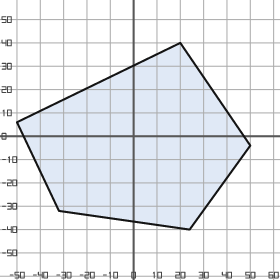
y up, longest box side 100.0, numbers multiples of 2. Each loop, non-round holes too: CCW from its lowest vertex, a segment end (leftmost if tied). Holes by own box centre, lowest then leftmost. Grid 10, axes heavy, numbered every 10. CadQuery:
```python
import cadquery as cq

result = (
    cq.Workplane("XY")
    .moveTo(24.0, -40.0)
    .lineTo(50.0, -4.0)
    .lineTo(20.0, 40.0)
    .lineTo(-50.0, 6.0)
    .lineTo(-32.0, -32.0)
    .close()
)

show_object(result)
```